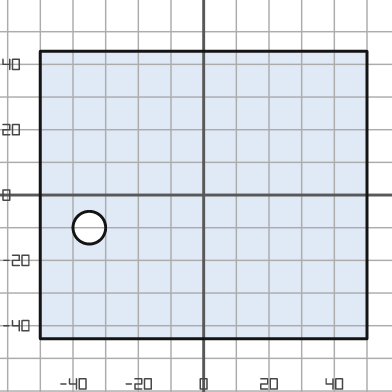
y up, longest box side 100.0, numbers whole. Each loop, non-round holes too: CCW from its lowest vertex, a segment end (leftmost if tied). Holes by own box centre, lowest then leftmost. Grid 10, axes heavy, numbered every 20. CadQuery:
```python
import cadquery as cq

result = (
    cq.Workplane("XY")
    .moveTo(-50.0, -44.0)
    .lineTo(50.0, -44.0)
    .lineTo(50.0, 44.0)
    .lineTo(-50.0, 44.0)
    .close()
    .moveTo(-35.0, -10.0)
    .circle(5.0)
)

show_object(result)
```